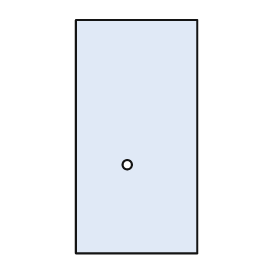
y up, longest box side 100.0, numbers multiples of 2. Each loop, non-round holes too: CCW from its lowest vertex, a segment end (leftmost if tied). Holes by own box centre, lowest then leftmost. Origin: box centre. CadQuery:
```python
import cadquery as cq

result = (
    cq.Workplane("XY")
    .moveTo(-26.0, -50.0)
    .lineTo(26.0, -50.0)
    .lineTo(26.0, 50.0)
    .lineTo(-26.0, 50.0)
    .close()
    .moveTo(-4.0, -12.0)
    .circle(2.0)
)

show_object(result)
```